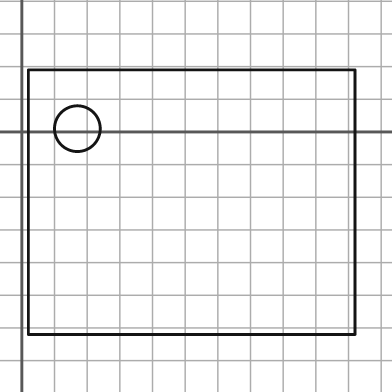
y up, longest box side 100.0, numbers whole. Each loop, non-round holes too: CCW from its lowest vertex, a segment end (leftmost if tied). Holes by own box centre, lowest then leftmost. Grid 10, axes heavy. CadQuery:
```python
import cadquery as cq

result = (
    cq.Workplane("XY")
    .moveTo(2.0, -62.0)
    .lineTo(102.0, -62.0)
    .lineTo(102.0, 19.0)
    .lineTo(2.0, 19.0)
    .close()
    .moveTo(17.0, 1.0)
    .circle(7.0)
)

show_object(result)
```